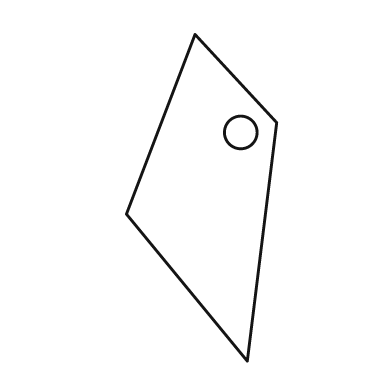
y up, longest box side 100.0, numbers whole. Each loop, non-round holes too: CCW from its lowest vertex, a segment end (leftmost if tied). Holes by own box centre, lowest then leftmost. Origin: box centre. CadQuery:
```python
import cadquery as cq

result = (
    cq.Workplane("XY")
    .moveTo(14.0, -50.0)
    .lineTo(23.0, 23.0)
    .lineTo(-2.0, 50.0)
    .lineTo(-23.0, -5.0)
    .close()
    .moveTo(12.0, 20.0)
    .circle(5.0)
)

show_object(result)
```